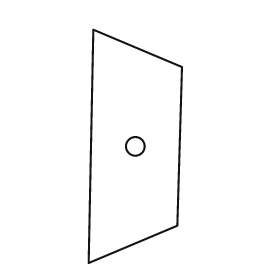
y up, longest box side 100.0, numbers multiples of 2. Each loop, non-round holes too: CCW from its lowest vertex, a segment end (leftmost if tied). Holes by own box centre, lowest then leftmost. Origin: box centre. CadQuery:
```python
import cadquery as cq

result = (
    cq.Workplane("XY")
    .moveTo(-20.0, -50.0)
    .lineTo(18.0, -34.0)
    .lineTo(20.0, 34.0)
    .lineTo(-18.0, 50.0)
    .close()
    .moveTo(0.0, 0.0)
    .circle(4.0)
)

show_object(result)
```